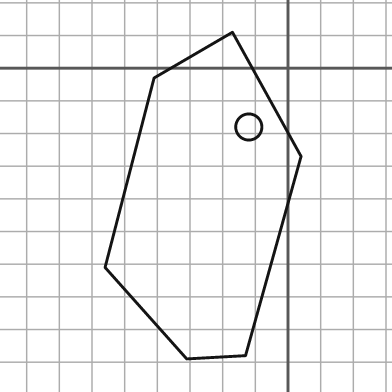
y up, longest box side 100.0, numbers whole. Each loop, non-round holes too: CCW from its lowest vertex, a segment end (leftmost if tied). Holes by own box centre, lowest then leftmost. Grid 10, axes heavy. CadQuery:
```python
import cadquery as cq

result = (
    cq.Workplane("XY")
    .moveTo(-31.0, -89.0)
    .lineTo(-13.0, -88.0)
    .lineTo(4.0, -27.0)
    .lineTo(-17.0, 11.0)
    .lineTo(-41.0, -3.0)
    .lineTo(-56.0, -61.0)
    .close()
    .moveTo(-12.0, -18.0)
    .circle(4.0)
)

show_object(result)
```